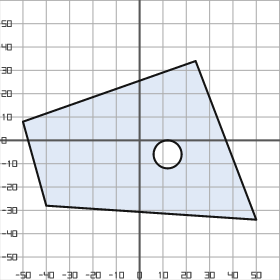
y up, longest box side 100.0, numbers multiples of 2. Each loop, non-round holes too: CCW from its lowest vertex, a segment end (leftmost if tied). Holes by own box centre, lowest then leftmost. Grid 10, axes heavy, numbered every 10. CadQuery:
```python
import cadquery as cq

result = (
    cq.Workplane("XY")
    .moveTo(50.0, -34.0)
    .lineTo(24.0, 34.0)
    .lineTo(-50.0, 8.0)
    .lineTo(-40.0, -28.0)
    .close()
    .moveTo(12.0, -6.0)
    .circle(6.0)
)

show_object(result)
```